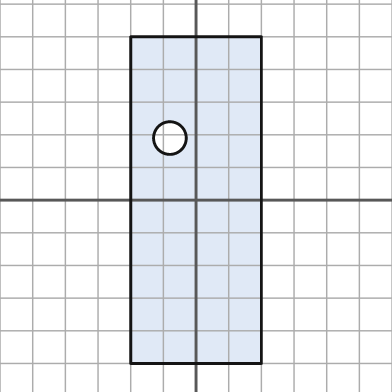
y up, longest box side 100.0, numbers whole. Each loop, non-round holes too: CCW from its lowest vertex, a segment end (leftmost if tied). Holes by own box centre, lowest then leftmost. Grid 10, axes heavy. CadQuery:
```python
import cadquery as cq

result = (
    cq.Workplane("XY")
    .moveTo(-20.0, -50.0)
    .lineTo(20.0, -50.0)
    .lineTo(20.0, 50.0)
    .lineTo(-20.0, 50.0)
    .close()
    .moveTo(-8.0, 19.0)
    .circle(5.0)
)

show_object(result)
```